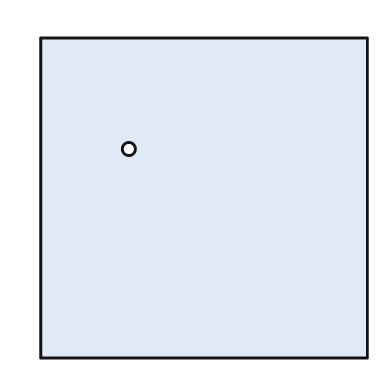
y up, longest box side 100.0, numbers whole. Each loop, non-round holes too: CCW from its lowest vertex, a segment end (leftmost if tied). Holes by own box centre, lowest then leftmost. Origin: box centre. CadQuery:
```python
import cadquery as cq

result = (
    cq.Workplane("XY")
    .moveTo(-50.0, -49.0)
    .lineTo(50.0, -49.0)
    .lineTo(50.0, 49.0)
    .lineTo(-50.0, 49.0)
    .close()
    .moveTo(-23.0, 15.0)
    .circle(2.0)
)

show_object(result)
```